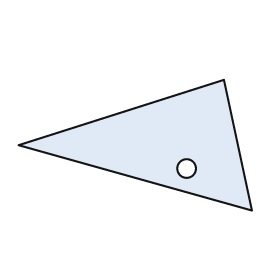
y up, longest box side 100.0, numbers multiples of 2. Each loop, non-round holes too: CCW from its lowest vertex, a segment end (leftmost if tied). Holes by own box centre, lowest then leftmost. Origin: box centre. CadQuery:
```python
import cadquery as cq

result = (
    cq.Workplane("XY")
    .moveTo(50.0, -28.0)
    .lineTo(38.0, 28.0)
    .lineTo(-50.0, 0.0)
    .close()
    .moveTo(22.0, -10.0)
    .circle(4.0)
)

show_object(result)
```